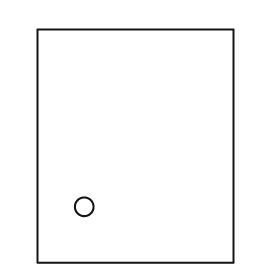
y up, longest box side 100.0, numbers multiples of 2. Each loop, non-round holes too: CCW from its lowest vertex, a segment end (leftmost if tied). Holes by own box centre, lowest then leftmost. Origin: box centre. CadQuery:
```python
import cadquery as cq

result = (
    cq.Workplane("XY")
    .moveTo(-42.0, -50.0)
    .lineTo(42.0, -50.0)
    .lineTo(42.0, 50.0)
    .lineTo(-42.0, 50.0)
    .close()
    .moveTo(-22.0, -26.0)
    .circle(4.0)
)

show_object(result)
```